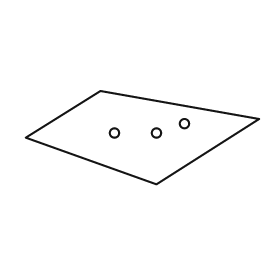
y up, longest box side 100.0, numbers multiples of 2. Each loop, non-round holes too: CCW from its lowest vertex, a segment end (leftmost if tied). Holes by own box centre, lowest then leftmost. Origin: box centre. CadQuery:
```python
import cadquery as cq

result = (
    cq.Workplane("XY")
    .moveTo(6.0, -20.0)
    .lineTo(50.0, 8.0)
    .lineTo(-18.0, 20.0)
    .lineTo(-50.0, 0.0)
    .close()
    .moveTo(-12.0, 2.0)
    .circle(2.0)
    .moveTo(6.0, 2.0)
    .circle(2.0)
    .moveTo(18.0, 6.0)
    .circle(2.0)
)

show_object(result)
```